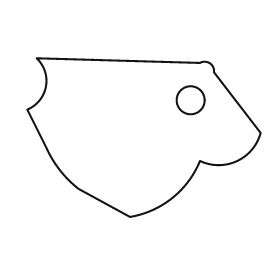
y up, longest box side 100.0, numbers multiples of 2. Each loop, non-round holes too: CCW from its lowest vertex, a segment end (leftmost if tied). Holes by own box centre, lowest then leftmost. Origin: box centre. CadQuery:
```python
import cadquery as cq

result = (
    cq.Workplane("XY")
    .moveTo(-6.0, -34.0)
    .threePointArc((12.0, -26.0), (24.0, -10.0))
    .threePointArc((40.0, -10.0), (50.0, 2.0))
    .lineTo(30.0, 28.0)
    .threePointArc((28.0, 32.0), (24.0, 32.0))
    .lineTo(-46.0, 34.0)
    .threePointArc((-42.0, 22.0), (-50.0, 12.0))
    .lineTo(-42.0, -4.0)
    .threePointArc((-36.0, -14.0), (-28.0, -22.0))
    .close()
    .moveTo(20.0, 16.0)
    .circle(6.0)
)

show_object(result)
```